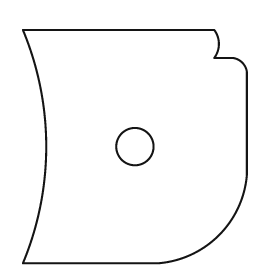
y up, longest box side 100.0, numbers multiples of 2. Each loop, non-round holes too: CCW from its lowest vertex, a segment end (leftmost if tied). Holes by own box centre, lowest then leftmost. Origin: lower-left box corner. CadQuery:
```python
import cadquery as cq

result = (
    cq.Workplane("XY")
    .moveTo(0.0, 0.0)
    .lineTo(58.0, 0.0)
    .threePointArc((84.0, 12.0), (96.0, 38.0))
    .lineTo(96.0, 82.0)
    .threePointArc((94.0, 86.0), (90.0, 88.0))
    .lineTo(82.0, 88.0)
    .threePointArc((84.0, 94.0), (82.0, 100.0))
    .lineTo(0.0, 100.0)
    .threePointArc((10.0, 50.0), (0.0, 0.0))
    .close()
    .moveTo(48.0, 50.0)
    .circle(8.0)
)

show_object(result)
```